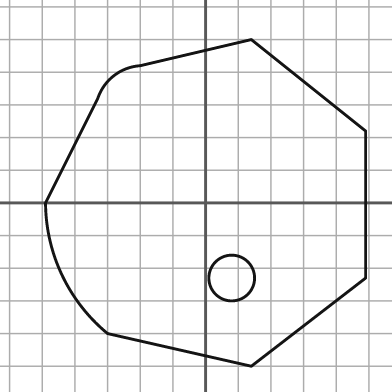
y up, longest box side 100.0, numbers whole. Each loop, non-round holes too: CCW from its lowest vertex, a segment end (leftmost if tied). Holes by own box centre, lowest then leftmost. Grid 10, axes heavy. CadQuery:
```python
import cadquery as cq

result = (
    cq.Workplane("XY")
    .moveTo(14.0, -50.0)
    .lineTo(49.0, -23.0)
    .lineTo(49.0, 22.0)
    .lineTo(14.0, 50.0)
    .lineTo(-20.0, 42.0)
    .threePointArc((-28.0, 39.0), (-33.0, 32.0))
    .lineTo(-49.0, 0.0)
    .threePointArc((-44.0, -22.0), (-30.0, -40.0))
    .close()
    .moveTo(8.0, -23.0)
    .circle(7.0)
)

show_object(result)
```